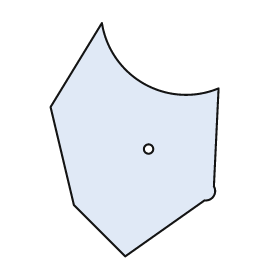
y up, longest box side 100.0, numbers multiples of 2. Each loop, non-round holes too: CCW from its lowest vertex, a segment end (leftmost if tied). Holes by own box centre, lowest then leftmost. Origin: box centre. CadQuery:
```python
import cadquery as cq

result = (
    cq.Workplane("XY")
    .moveTo(-4.0, -50.0)
    .lineTo(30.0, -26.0)
    .threePointArc((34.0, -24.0), (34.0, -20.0))
    .lineTo(36.0, 22.0)
    .threePointArc((4.0, 24.0), (-14.0, 50.0))
    .lineTo(-36.0, 14.0)
    .lineTo(-26.0, -28.0)
    .close()
    .moveTo(6.0, -4.0)
    .circle(2.0)
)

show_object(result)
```